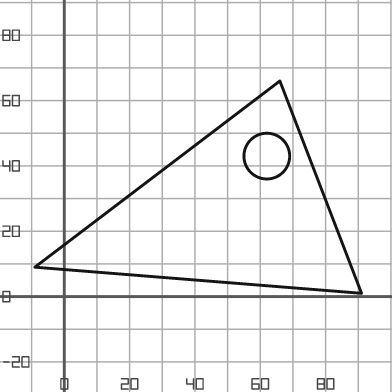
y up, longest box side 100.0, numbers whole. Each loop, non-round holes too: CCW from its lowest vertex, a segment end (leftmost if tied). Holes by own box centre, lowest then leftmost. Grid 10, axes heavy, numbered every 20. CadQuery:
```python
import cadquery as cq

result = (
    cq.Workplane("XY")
    .moveTo(91.0, 1.0)
    .lineTo(66.0, 66.0)
    .lineTo(-9.0, 9.0)
    .close()
    .moveTo(62.0, 43.0)
    .circle(7.0)
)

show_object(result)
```